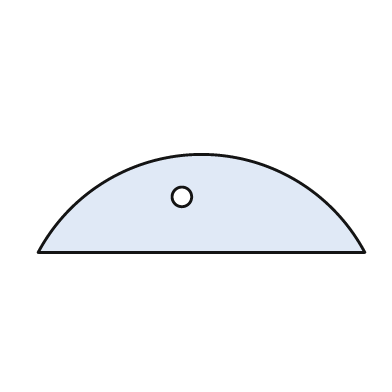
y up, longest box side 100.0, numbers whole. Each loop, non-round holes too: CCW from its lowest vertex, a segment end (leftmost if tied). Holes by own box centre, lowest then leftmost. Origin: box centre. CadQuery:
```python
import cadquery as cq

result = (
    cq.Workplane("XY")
    .moveTo(-50.0, -15.0)
    .lineTo(50.0, -15.0)
    .threePointArc((0.0, 15.0), (-50.0, -15.0))
    .close()
    .moveTo(-6.0, 2.0)
    .circle(3.0)
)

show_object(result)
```